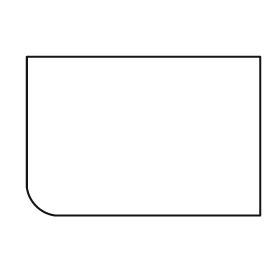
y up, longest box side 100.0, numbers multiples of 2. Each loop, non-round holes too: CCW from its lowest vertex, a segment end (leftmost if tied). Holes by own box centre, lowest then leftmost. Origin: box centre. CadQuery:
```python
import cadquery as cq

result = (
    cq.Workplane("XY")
    .moveTo(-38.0, -34.0)
    .lineTo(50.0, -34.0)
    .lineTo(50.0, 34.0)
    .lineTo(-50.0, 34.0)
    .lineTo(-50.0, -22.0)
    .threePointArc((-46.0, -30.0), (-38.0, -34.0))
    .close()
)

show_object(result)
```